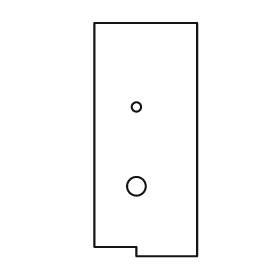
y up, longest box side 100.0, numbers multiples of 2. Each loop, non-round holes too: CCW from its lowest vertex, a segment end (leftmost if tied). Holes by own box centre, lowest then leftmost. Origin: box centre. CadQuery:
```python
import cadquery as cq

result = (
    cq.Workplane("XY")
    .moveTo(-4.0, -50.0)
    .lineTo(22.0, -50.0)
    .lineTo(22.0, 50.0)
    .lineTo(-22.0, 50.0)
    .lineTo(-22.0, -46.0)
    .lineTo(-4.0, -46.0)
    .close()
    .moveTo(-4.0, -20.0)
    .circle(4.0)
    .moveTo(-4.0, 14.0)
    .circle(2.0)
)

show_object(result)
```